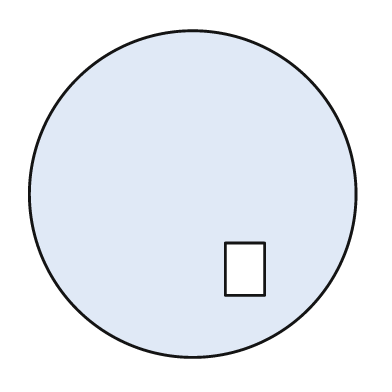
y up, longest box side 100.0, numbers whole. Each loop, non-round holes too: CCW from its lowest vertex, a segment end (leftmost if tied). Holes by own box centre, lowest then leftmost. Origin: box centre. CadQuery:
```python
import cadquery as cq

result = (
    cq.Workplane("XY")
    .moveTo(0.0, 0.0)
    .circle(50.0)
    .moveTo(10.0, -31.0)
    .lineTo(22.0, -31.0)
    .lineTo(22.0, -15.0)
    .lineTo(10.0, -15.0)
    .close()
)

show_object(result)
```